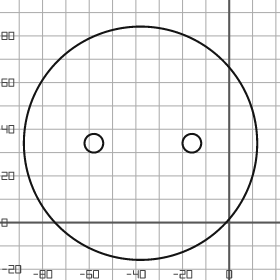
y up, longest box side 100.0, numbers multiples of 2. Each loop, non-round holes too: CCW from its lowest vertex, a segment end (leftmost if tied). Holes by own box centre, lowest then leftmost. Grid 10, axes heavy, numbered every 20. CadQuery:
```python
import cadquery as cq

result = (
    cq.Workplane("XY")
    .moveTo(-38.0, 34.0)
    .circle(50.0)
    .moveTo(-58.0, 34.0)
    .circle(4.0)
    .moveTo(-16.0, 34.0)
    .circle(4.0)
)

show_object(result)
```